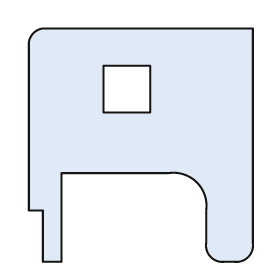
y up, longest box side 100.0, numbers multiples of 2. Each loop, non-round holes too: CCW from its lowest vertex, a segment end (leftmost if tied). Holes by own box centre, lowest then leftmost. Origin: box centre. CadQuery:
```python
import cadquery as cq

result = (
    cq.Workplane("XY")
    .moveTo(-42.0, -50.0)
    .lineTo(-34.0, -50.0)
    .lineTo(-34.0, -12.0)
    .lineTo(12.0, -12.0)
    .threePointArc((24.0, -16.0), (28.0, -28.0))
    .lineTo(28.0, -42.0)
    .threePointArc((30.0, -48.0), (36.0, -50.0))
    .lineTo(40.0, -50.0)
    .threePointArc((46.0, -48.0), (48.0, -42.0))
    .lineTo(48.0, 50.0)
    .lineTo(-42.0, 50.0)
    .threePointArc((-46.0, 48.0), (-48.0, 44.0))
    .lineTo(-48.0, -28.0)
    .lineTo(-42.0, -28.0)
    .close()
    .moveTo(-16.0, 14.0)
    .lineTo(4.0, 14.0)
    .lineTo(4.0, 34.0)
    .lineTo(-16.0, 34.0)
    .close()
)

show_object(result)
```